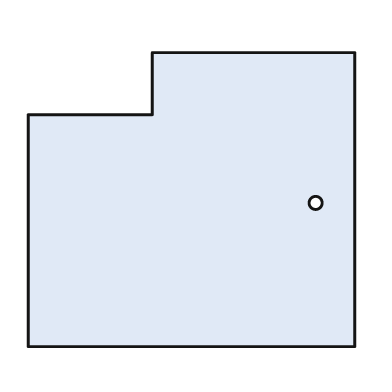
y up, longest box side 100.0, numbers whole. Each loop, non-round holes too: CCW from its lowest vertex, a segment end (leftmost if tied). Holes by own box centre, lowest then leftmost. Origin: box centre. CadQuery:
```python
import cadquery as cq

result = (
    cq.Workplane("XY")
    .moveTo(-50.0, -45.0)
    .lineTo(50.0, -45.0)
    .lineTo(50.0, 45.0)
    .lineTo(-12.0, 45.0)
    .lineTo(-12.0, 26.0)
    .lineTo(-50.0, 26.0)
    .close()
    .moveTo(38.0, -1.0)
    .circle(2.0)
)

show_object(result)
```